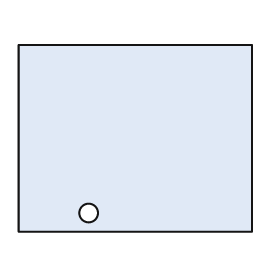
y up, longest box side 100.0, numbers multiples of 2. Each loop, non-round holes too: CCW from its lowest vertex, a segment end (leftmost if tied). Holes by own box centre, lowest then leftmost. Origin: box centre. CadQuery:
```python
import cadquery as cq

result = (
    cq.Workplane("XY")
    .moveTo(-50.0, -40.0)
    .lineTo(50.0, -40.0)
    .lineTo(50.0, 40.0)
    .lineTo(-50.0, 40.0)
    .close()
    .moveTo(-20.0, -32.0)
    .circle(4.0)
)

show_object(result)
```